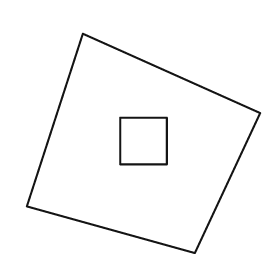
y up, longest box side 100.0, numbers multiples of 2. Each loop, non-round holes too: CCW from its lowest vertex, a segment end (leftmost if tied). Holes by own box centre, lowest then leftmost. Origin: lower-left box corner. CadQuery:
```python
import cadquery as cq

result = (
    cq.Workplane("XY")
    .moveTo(72.0, 0.0)
    .lineTo(100.0, 60.0)
    .lineTo(24.0, 94.0)
    .lineTo(0.0, 20.0)
    .close()
    .moveTo(40.0, 38.0)
    .lineTo(60.0, 38.0)
    .lineTo(60.0, 58.0)
    .lineTo(40.0, 58.0)
    .close()
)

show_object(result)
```